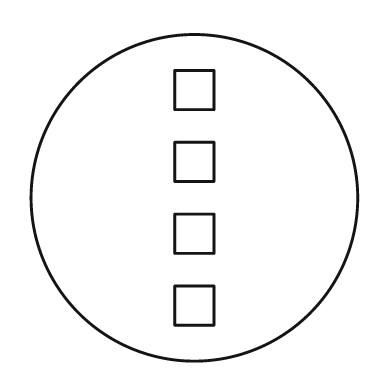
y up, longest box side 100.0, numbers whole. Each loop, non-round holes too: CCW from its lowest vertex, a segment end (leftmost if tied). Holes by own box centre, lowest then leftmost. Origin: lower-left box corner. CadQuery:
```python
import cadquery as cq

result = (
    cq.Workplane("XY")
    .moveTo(50.0, 50.0)
    .circle(50.0)
    .moveTo(44.0, 11.0)
    .lineTo(56.0, 11.0)
    .lineTo(56.0, 23.0)
    .lineTo(44.0, 23.0)
    .close()
    .moveTo(44.0, 33.0)
    .lineTo(56.0, 33.0)
    .lineTo(56.0, 45.0)
    .lineTo(44.0, 45.0)
    .close()
    .moveTo(44.0, 55.0)
    .lineTo(56.0, 55.0)
    .lineTo(56.0, 67.0)
    .lineTo(44.0, 67.0)
    .close()
    .moveTo(44.0, 77.0)
    .lineTo(56.0, 77.0)
    .lineTo(56.0, 89.0)
    .lineTo(44.0, 89.0)
    .close()
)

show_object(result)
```